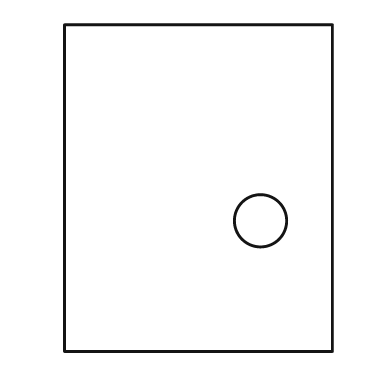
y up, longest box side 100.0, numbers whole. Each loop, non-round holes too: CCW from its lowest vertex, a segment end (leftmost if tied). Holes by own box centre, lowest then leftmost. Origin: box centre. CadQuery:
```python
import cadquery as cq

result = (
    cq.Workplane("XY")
    .moveTo(-41.0, -50.0)
    .lineTo(41.0, -50.0)
    .lineTo(41.0, 50.0)
    .lineTo(-41.0, 50.0)
    .close()
    .moveTo(19.0, -10.0)
    .circle(8.0)
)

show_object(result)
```